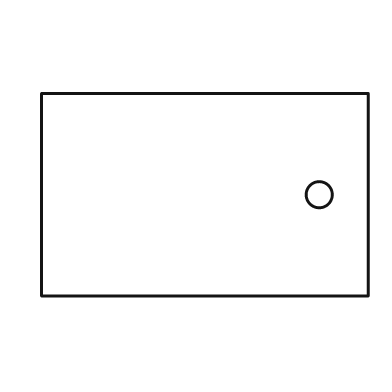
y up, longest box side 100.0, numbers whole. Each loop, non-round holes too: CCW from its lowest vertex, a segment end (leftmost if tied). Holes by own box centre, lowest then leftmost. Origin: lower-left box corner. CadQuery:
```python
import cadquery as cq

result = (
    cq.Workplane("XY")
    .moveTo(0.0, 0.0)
    .lineTo(100.0, 0.0)
    .lineTo(100.0, 62.0)
    .lineTo(0.0, 62.0)
    .close()
    .moveTo(85.0, 31.0)
    .circle(4.0)
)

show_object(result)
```